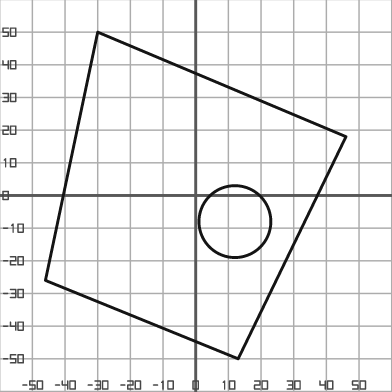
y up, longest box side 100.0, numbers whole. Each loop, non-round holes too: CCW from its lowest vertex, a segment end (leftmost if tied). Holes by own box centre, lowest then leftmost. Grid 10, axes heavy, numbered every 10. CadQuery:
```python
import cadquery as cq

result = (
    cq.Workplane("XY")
    .moveTo(13.0, -50.0)
    .lineTo(46.0, 18.0)
    .lineTo(-30.0, 50.0)
    .lineTo(-46.0, -26.0)
    .close()
    .moveTo(12.0, -8.0)
    .circle(11.0)
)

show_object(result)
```